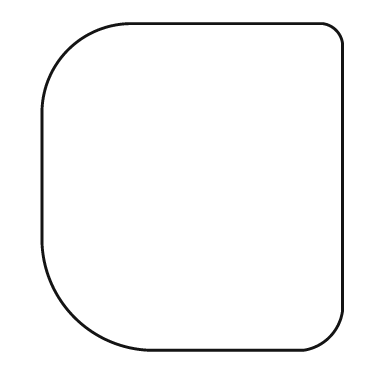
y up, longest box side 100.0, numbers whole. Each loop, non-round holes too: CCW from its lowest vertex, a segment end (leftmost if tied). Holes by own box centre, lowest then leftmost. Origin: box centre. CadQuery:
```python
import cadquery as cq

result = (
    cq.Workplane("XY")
    .moveTo(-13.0, -50.0)
    .lineTo(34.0, -50.0)
    .threePointArc((42.0, -46.0), (46.0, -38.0))
    .lineTo(46.0, 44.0)
    .threePointArc((44.0, 48.0), (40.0, 50.0))
    .lineTo(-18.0, 50.0)
    .threePointArc((-38.0, 42.0), (-46.0, 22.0))
    .lineTo(-46.0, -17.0)
    .threePointArc((-36.0, -40.0), (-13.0, -50.0))
    .close()
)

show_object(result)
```